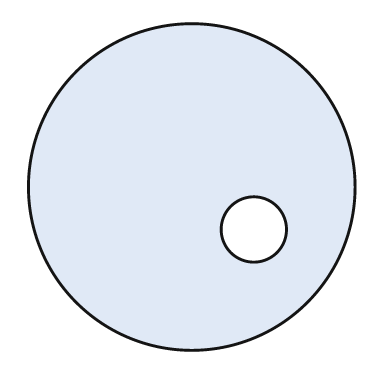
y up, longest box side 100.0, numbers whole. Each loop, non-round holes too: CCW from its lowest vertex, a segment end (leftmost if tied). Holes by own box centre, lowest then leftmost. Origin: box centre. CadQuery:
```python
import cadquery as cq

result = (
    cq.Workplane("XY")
    .moveTo(0.0, 0.0)
    .circle(50.0)
    .moveTo(19.0, -13.0)
    .circle(10.0)
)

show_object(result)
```